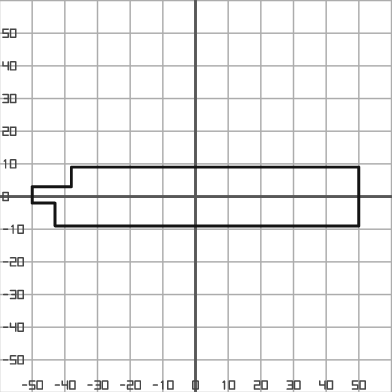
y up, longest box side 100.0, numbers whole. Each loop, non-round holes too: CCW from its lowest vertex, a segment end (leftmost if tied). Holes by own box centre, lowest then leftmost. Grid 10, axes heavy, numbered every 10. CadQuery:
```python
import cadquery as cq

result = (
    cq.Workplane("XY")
    .moveTo(-43.0, -9.0)
    .lineTo(50.0, -9.0)
    .lineTo(50.0, 9.0)
    .lineTo(-38.0, 9.0)
    .lineTo(-38.0, 3.0)
    .lineTo(-50.0, 3.0)
    .lineTo(-50.0, -2.0)
    .lineTo(-43.0, -2.0)
    .close()
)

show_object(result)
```